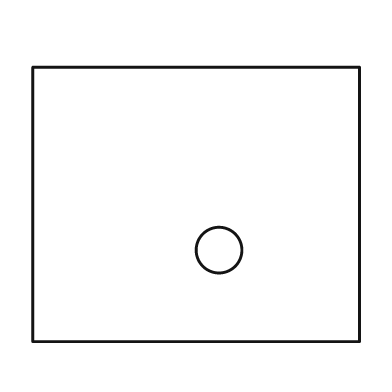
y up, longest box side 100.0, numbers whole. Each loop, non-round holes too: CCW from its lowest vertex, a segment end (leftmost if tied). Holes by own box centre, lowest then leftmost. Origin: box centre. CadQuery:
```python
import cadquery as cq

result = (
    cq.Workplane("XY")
    .moveTo(-50.0, -42.0)
    .lineTo(50.0, -42.0)
    .lineTo(50.0, 42.0)
    .lineTo(-50.0, 42.0)
    .close()
    .moveTo(7.0, -14.0)
    .circle(7.0)
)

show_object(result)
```